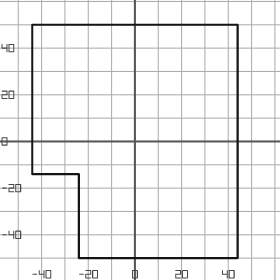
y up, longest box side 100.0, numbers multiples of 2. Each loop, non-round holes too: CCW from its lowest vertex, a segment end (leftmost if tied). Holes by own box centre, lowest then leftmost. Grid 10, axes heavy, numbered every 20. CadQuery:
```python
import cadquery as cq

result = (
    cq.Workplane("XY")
    .moveTo(-24.0, -50.0)
    .lineTo(44.0, -50.0)
    .lineTo(44.0, 50.0)
    .lineTo(-44.0, 50.0)
    .lineTo(-44.0, -14.0)
    .lineTo(-24.0, -14.0)
    .close()
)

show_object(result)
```